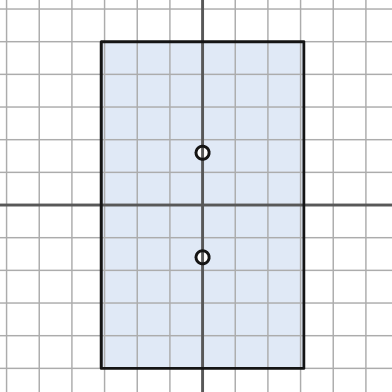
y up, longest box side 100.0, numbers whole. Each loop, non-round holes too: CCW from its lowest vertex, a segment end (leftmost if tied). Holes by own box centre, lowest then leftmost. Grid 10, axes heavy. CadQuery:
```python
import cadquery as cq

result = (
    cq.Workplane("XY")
    .moveTo(-31.0, -50.0)
    .lineTo(31.0, -50.0)
    .lineTo(31.0, 50.0)
    .lineTo(-31.0, 50.0)
    .close()
    .moveTo(0.0, -16.0)
    .circle(2.0)
    .moveTo(0.0, 16.0)
    .circle(2.0)
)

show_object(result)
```